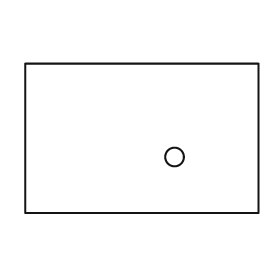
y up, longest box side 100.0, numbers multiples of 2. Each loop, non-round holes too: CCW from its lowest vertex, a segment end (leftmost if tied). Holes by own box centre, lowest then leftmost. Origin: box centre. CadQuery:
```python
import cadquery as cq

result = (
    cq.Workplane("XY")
    .moveTo(-50.0, -32.0)
    .lineTo(50.0, -32.0)
    .lineTo(50.0, 32.0)
    .lineTo(-50.0, 32.0)
    .close()
    .moveTo(14.0, -8.0)
    .circle(4.0)
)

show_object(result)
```